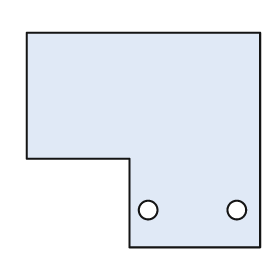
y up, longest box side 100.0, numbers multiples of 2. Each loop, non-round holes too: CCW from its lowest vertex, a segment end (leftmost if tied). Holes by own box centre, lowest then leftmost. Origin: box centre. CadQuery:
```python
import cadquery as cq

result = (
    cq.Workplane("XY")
    .moveTo(-6.0, -46.0)
    .lineTo(50.0, -46.0)
    .lineTo(50.0, 46.0)
    .lineTo(-50.0, 46.0)
    .lineTo(-50.0, -8.0)
    .lineTo(-6.0, -8.0)
    .close()
    .moveTo(2.0, -30.0)
    .circle(4.0)
    .moveTo(40.0, -30.0)
    .circle(4.0)
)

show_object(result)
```